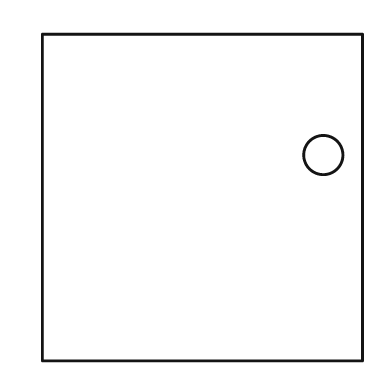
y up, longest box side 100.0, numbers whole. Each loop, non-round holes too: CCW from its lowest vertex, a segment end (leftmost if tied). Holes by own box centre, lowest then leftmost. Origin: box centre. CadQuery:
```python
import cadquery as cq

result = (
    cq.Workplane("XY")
    .moveTo(-49.0, -50.0)
    .lineTo(49.0, -50.0)
    .lineTo(49.0, 50.0)
    .lineTo(-49.0, 50.0)
    .close()
    .moveTo(37.0, 13.0)
    .circle(6.0)
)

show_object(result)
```